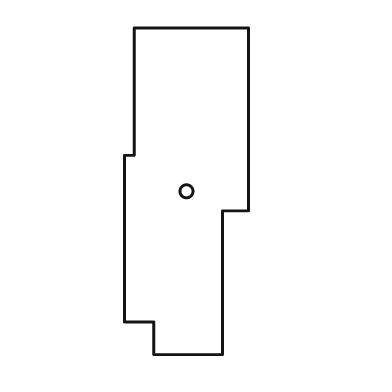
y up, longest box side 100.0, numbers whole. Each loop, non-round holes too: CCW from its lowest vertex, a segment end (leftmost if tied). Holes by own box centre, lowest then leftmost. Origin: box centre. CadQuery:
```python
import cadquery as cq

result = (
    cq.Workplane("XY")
    .moveTo(-10.0, -50.0)
    .lineTo(11.0, -50.0)
    .lineTo(11.0, -6.0)
    .lineTo(19.0, -6.0)
    .lineTo(19.0, 50.0)
    .lineTo(-16.0, 50.0)
    .lineTo(-16.0, 11.0)
    .lineTo(-19.0, 11.0)
    .lineTo(-19.0, -40.0)
    .lineTo(-10.0, -40.0)
    .close()
    .moveTo(0.0, 0.0)
    .circle(2.0)
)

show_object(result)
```